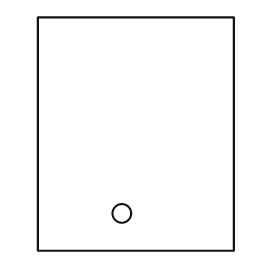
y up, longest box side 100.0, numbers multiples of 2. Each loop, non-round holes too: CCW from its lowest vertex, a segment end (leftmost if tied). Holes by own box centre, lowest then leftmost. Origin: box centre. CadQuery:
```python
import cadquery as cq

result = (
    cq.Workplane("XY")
    .moveTo(-42.0, -50.0)
    .lineTo(42.0, -50.0)
    .lineTo(42.0, 50.0)
    .lineTo(-42.0, 50.0)
    .close()
    .moveTo(-6.0, -34.0)
    .circle(4.0)
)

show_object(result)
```